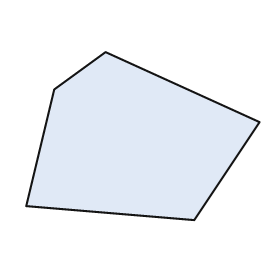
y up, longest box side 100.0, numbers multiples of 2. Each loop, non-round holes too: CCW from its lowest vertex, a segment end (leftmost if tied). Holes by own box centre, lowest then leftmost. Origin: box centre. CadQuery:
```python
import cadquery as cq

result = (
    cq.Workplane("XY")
    .moveTo(22.0, -36.0)
    .lineTo(50.0, 6.0)
    .lineTo(-16.0, 36.0)
    .lineTo(-38.0, 20.0)
    .lineTo(-50.0, -30.0)
    .close()
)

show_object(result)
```